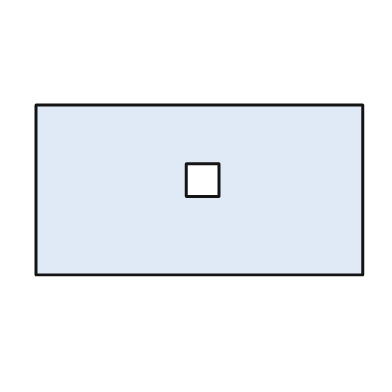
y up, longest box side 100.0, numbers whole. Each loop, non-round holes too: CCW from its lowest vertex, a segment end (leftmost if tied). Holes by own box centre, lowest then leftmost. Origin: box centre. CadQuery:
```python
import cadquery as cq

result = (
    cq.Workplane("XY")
    .moveTo(-50.0, -26.0)
    .lineTo(50.0, -26.0)
    .lineTo(50.0, 26.0)
    .lineTo(-50.0, 26.0)
    .close()
    .moveTo(-4.0, -2.0)
    .lineTo(6.0, -2.0)
    .lineTo(6.0, 8.0)
    .lineTo(-4.0, 8.0)
    .close()
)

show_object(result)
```